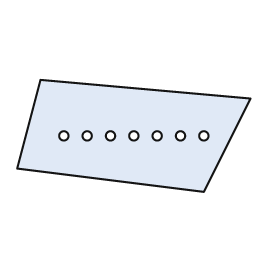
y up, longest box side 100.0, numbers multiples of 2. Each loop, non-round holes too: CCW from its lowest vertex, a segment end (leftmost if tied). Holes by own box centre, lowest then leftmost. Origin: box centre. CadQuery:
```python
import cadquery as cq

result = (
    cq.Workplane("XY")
    .moveTo(30.0, -24.0)
    .lineTo(50.0, 16.0)
    .lineTo(-40.0, 24.0)
    .lineTo(-50.0, -14.0)
    .close()
    .moveTo(-30.0, 0.0)
    .circle(2.0)
    .moveTo(-20.0, 0.0)
    .circle(2.0)
    .moveTo(-10.0, 0.0)
    .circle(2.0)
    .moveTo(0.0, 0.0)
    .circle(2.0)
    .moveTo(10.0, 0.0)
    .circle(2.0)
    .moveTo(20.0, 0.0)
    .circle(2.0)
    .moveTo(30.0, 0.0)
    .circle(2.0)
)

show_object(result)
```